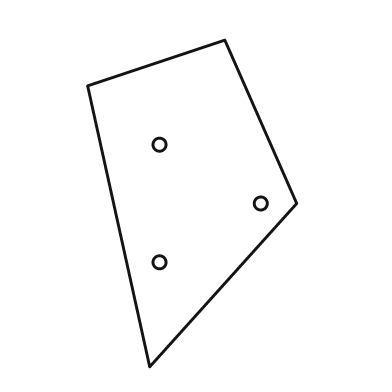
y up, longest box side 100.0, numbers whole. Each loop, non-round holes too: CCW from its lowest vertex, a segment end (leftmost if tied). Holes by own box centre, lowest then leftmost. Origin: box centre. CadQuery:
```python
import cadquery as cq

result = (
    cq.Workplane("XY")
    .moveTo(-13.0, -50.0)
    .lineTo(32.0, 0.0)
    .lineTo(10.0, 50.0)
    .lineTo(-32.0, 36.0)
    .close()
    .moveTo(-10.0, -18.0)
    .circle(2.0)
    .moveTo(21.0, 0.0)
    .circle(2.0)
    .moveTo(-10.0, 18.0)
    .circle(2.0)
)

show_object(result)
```